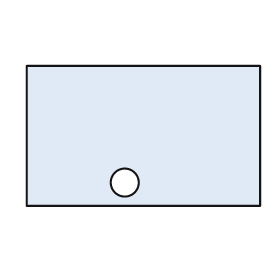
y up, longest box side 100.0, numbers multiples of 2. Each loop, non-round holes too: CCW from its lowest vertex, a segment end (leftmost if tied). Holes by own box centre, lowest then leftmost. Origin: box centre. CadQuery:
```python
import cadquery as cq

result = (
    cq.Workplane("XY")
    .moveTo(-50.0, -30.0)
    .lineTo(50.0, -30.0)
    .lineTo(50.0, 30.0)
    .lineTo(-50.0, 30.0)
    .close()
    .moveTo(-8.0, -20.0)
    .circle(6.0)
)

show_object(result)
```